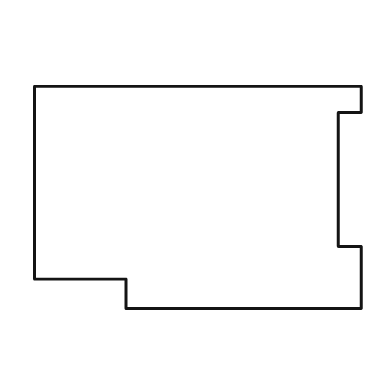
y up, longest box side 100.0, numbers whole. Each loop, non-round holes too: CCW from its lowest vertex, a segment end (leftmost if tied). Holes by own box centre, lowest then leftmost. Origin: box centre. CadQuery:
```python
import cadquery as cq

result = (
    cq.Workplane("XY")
    .moveTo(-22.0, -34.0)
    .lineTo(50.0, -34.0)
    .lineTo(50.0, -15.0)
    .lineTo(43.0, -15.0)
    .lineTo(43.0, 26.0)
    .lineTo(50.0, 26.0)
    .lineTo(50.0, 34.0)
    .lineTo(-50.0, 34.0)
    .lineTo(-50.0, -25.0)
    .lineTo(-22.0, -25.0)
    .close()
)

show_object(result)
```